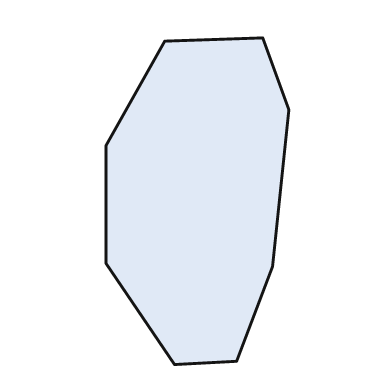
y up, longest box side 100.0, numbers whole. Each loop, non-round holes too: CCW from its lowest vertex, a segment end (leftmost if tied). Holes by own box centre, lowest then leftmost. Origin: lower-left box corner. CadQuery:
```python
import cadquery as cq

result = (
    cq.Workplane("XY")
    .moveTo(21.0, 0.0)
    .lineTo(40.0, 1.0)
    .lineTo(51.0, 30.0)
    .lineTo(56.0, 78.0)
    .lineTo(48.0, 100.0)
    .lineTo(18.0, 99.0)
    .lineTo(0.0, 67.0)
    .lineTo(0.0, 31.0)
    .close()
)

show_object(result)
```